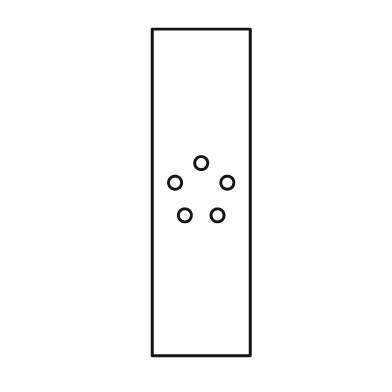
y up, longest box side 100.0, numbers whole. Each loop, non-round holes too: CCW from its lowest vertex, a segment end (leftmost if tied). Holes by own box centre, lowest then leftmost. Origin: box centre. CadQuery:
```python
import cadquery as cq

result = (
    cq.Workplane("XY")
    .moveTo(-15.0, -50.0)
    .lineTo(15.0, -50.0)
    .lineTo(15.0, 50.0)
    .lineTo(-15.0, 50.0)
    .close()
    .moveTo(-5.0, -7.0)
    .circle(2.0)
    .moveTo(5.0, -7.0)
    .circle(2.0)
    .moveTo(-8.0, 3.0)
    .circle(2.0)
    .moveTo(8.0, 3.0)
    .circle(2.0)
    .moveTo(0.0, 9.0)
    .circle(2.0)
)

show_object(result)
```